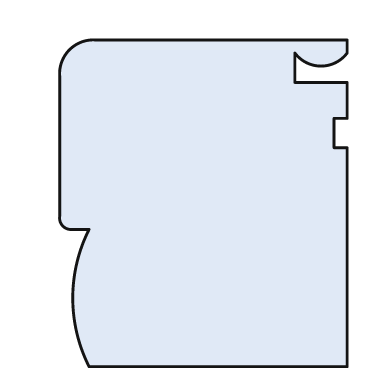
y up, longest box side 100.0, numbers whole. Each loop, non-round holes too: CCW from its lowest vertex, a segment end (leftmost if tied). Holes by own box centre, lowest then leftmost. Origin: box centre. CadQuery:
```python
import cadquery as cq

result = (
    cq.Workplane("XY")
    .moveTo(-35.0, -50.0)
    .lineTo(44.0, -50.0)
    .lineTo(44.0, 17.0)
    .lineTo(40.0, 17.0)
    .lineTo(40.0, 26.0)
    .lineTo(44.0, 26.0)
    .lineTo(44.0, 37.0)
    .lineTo(28.0, 37.0)
    .lineTo(28.0, 46.0)
    .threePointArc((36.0, 42.0), (44.0, 46.0))
    .lineTo(44.0, 50.0)
    .lineTo(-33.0, 50.0)
    .threePointArc((-41.0, 47.0), (-44.0, 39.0))
    .lineTo(-44.0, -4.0)
    .threePointArc((-43.0, -7.0), (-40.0, -8.0))
    .lineTo(-35.0, -8.0)
    .threePointArc((-40.0, -29.0), (-35.0, -50.0))
    .close()
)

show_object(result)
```